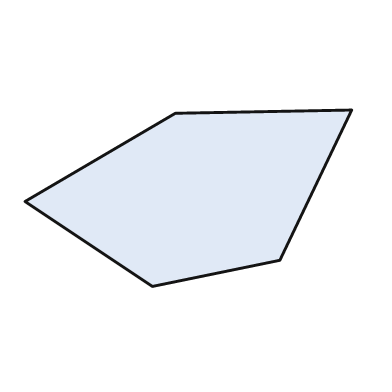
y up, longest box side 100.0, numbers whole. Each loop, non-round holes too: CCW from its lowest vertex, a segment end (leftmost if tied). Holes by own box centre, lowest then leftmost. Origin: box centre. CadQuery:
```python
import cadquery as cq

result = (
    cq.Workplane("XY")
    .moveTo(-11.0, -27.0)
    .lineTo(28.0, -19.0)
    .lineTo(50.0, 27.0)
    .lineTo(-4.0, 26.0)
    .lineTo(-50.0, -1.0)
    .close()
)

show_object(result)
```